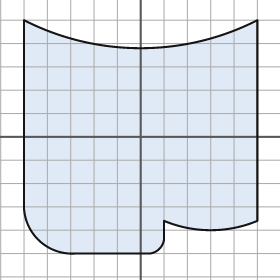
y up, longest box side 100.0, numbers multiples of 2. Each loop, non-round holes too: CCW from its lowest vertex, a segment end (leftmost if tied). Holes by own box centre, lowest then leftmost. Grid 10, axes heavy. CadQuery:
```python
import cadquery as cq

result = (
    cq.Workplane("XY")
    .moveTo(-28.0, -50.0)
    .lineTo(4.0, -50.0)
    .threePointArc((8.0, -48.0), (10.0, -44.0))
    .lineTo(10.0, -36.0)
    .threePointArc((30.0, -40.0), (50.0, -36.0))
    .lineTo(50.0, 50.0)
    .threePointArc((0.0, 38.0), (-50.0, 50.0))
    .lineTo(-50.0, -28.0)
    .threePointArc((-44.0, -44.0), (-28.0, -50.0))
    .close()
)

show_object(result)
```